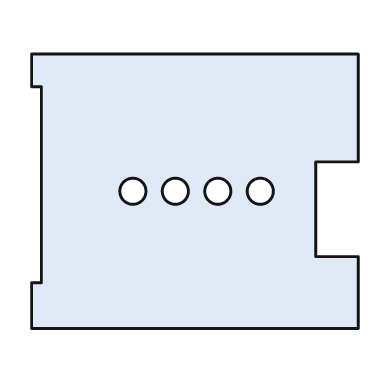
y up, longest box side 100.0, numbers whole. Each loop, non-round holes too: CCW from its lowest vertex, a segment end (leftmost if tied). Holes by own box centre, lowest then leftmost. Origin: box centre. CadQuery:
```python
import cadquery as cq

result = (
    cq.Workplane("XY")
    .moveTo(-50.0, -42.0)
    .lineTo(50.0, -42.0)
    .lineTo(50.0, -20.0)
    .lineTo(37.0, -20.0)
    .lineTo(37.0, 9.0)
    .lineTo(50.0, 9.0)
    .lineTo(50.0, 42.0)
    .lineTo(-50.0, 42.0)
    .lineTo(-50.0, 32.0)
    .lineTo(-47.0, 32.0)
    .lineTo(-47.0, -28.0)
    .lineTo(-50.0, -28.0)
    .close()
    .moveTo(-19.0, 0.0)
    .circle(4.0)
    .moveTo(-6.0, 0.0)
    .circle(4.0)
    .moveTo(7.0, 0.0)
    .circle(4.0)
    .moveTo(20.0, 0.0)
    .circle(4.0)
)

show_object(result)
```